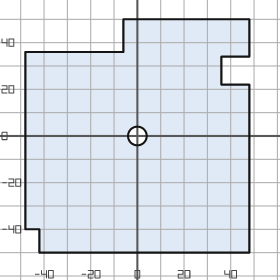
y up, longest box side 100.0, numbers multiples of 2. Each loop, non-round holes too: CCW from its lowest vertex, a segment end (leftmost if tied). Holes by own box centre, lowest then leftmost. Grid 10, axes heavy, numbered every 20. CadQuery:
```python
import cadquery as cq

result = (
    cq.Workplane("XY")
    .moveTo(-42.0, -50.0)
    .lineTo(48.0, -50.0)
    .lineTo(48.0, 22.0)
    .lineTo(36.0, 22.0)
    .lineTo(36.0, 34.0)
    .lineTo(48.0, 34.0)
    .lineTo(48.0, 50.0)
    .lineTo(-6.0, 50.0)
    .lineTo(-6.0, 36.0)
    .lineTo(-48.0, 36.0)
    .lineTo(-48.0, -40.0)
    .lineTo(-42.0, -40.0)
    .close()
    .moveTo(0.0, 0.0)
    .circle(4.0)
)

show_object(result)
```